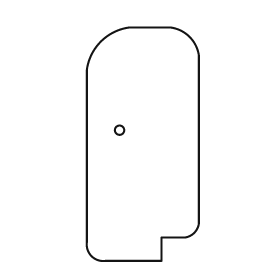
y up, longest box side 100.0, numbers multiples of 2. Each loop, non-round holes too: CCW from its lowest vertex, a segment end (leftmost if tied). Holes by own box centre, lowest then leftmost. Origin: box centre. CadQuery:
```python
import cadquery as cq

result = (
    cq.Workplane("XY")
    .moveTo(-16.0, -50.0)
    .lineTo(8.0, -50.0)
    .lineTo(8.0, -40.0)
    .lineTo(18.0, -40.0)
    .threePointArc((22.0, -38.0), (24.0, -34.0))
    .lineTo(24.0, 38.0)
    .threePointArc((20.0, 46.0), (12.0, 50.0))
    .lineTo(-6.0, 50.0)
    .threePointArc((-18.0, 44.0), (-24.0, 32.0))
    .lineTo(-24.0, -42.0)
    .threePointArc((-22.0, -48.0), (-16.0, -50.0))
    .close()
    .moveTo(-10.0, 6.0)
    .circle(2.0)
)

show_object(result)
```